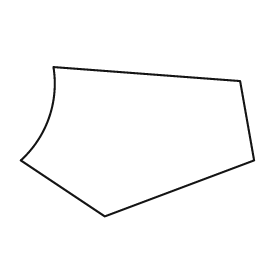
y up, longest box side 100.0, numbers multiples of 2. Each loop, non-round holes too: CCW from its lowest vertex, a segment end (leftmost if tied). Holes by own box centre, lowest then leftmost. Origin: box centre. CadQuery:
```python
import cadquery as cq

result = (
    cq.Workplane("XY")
    .moveTo(-14.0, -32.0)
    .lineTo(50.0, -8.0)
    .lineTo(44.0, 26.0)
    .lineTo(-36.0, 32.0)
    .threePointArc((-38.0, 10.0), (-50.0, -8.0))
    .close()
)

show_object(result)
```